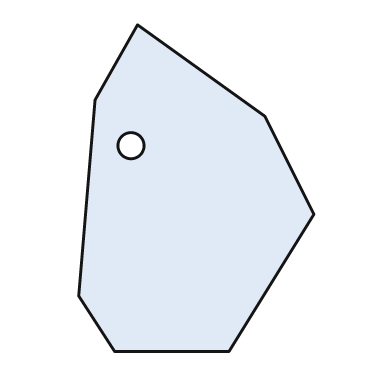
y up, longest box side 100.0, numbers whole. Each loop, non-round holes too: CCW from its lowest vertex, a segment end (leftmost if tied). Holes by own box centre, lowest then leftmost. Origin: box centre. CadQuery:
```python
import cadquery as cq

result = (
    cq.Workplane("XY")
    .moveTo(-25.0, -50.0)
    .lineTo(10.0, -50.0)
    .lineTo(36.0, -8.0)
    .lineTo(21.0, 22.0)
    .lineTo(-18.0, 50.0)
    .lineTo(-31.0, 27.0)
    .lineTo(-36.0, -33.0)
    .close()
    .moveTo(-20.0, 13.0)
    .circle(4.0)
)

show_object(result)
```